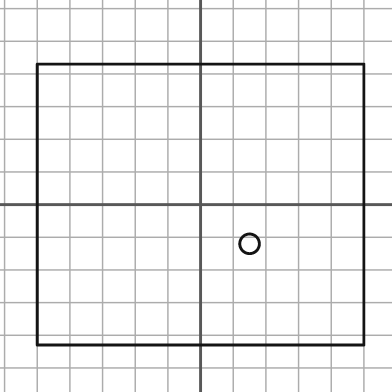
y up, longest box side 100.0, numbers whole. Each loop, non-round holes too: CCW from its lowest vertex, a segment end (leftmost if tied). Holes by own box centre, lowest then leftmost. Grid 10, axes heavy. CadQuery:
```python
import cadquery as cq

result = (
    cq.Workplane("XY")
    .moveTo(-50.0, -43.0)
    .lineTo(50.0, -43.0)
    .lineTo(50.0, 43.0)
    .lineTo(-50.0, 43.0)
    .close()
    .moveTo(15.0, -12.0)
    .circle(3.0)
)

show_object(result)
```